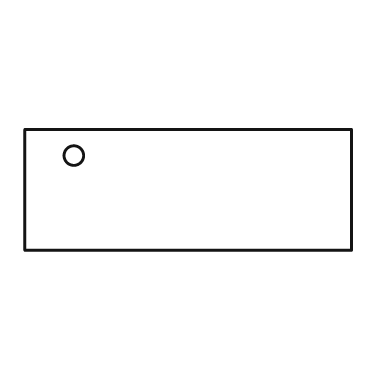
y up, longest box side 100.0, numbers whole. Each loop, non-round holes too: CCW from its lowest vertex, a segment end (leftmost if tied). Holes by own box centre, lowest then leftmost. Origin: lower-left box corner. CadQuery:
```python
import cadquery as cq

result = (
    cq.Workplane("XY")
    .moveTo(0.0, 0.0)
    .lineTo(100.0, 0.0)
    .lineTo(100.0, 37.0)
    .lineTo(0.0, 37.0)
    .close()
    .moveTo(15.0, 29.0)
    .circle(3.0)
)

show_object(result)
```